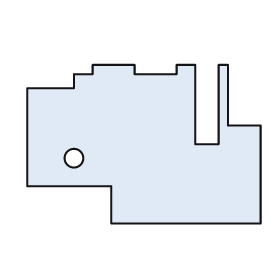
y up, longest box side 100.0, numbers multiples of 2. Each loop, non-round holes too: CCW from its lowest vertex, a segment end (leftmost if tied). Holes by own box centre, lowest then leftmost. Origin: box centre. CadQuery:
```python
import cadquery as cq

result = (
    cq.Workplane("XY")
    .moveTo(-14.0, -34.0)
    .lineTo(50.0, -34.0)
    .lineTo(50.0, 8.0)
    .lineTo(36.0, 8.0)
    .lineTo(36.0, 34.0)
    .lineTo(32.0, 34.0)
    .lineTo(32.0, 0.0)
    .lineTo(22.0, 0.0)
    .lineTo(22.0, 34.0)
    .lineTo(14.0, 34.0)
    .lineTo(14.0, 30.0)
    .lineTo(-4.0, 30.0)
    .lineTo(-4.0, 34.0)
    .lineTo(-22.0, 34.0)
    .lineTo(-22.0, 30.0)
    .lineTo(-30.0, 30.0)
    .lineTo(-30.0, 24.0)
    .lineTo(-50.0, 24.0)
    .lineTo(-50.0, -18.0)
    .lineTo(-14.0, -18.0)
    .close()
    .moveTo(-30.0, -6.0)
    .circle(4.0)
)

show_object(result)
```